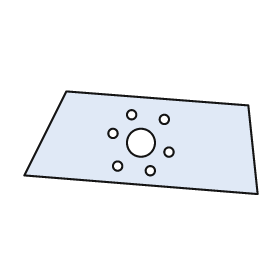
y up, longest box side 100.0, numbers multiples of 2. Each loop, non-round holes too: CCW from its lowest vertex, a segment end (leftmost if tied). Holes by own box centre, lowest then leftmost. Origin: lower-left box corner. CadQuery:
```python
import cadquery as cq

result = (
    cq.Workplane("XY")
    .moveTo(100.0, 0.0)
    .lineTo(96.0, 38.0)
    .lineTo(18.0, 44.0)
    .lineTo(0.0, 8.0)
    .close()
    .moveTo(54.0, 10.0)
    .circle(2.0)
    .moveTo(40.0, 12.0)
    .circle(2.0)
    .moveTo(62.0, 18.0)
    .circle(2.0)
    .moveTo(50.0, 22.0)
    .circle(6.0)
    .moveTo(38.0, 26.0)
    .circle(2.0)
    .moveTo(60.0, 32.0)
    .circle(2.0)
    .moveTo(46.0, 34.0)
    .circle(2.0)
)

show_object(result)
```